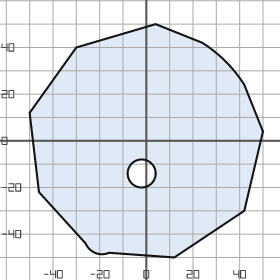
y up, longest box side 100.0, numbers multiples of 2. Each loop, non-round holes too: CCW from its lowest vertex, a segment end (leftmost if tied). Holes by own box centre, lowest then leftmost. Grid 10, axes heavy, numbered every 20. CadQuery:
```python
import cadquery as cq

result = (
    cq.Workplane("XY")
    .moveTo(12.0, -50.0)
    .lineTo(42.0, -30.0)
    .lineTo(50.0, 4.0)
    .lineTo(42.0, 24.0)
    .threePointArc((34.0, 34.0), (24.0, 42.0))
    .lineTo(4.0, 50.0)
    .lineTo(-30.0, 40.0)
    .lineTo(-50.0, 12.0)
    .lineTo(-46.0, -22.0)
    .lineTo(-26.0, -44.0)
    .threePointArc((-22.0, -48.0), (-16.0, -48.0))
    .close()
    .moveTo(-2.0, -14.0)
    .circle(6.0)
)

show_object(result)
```